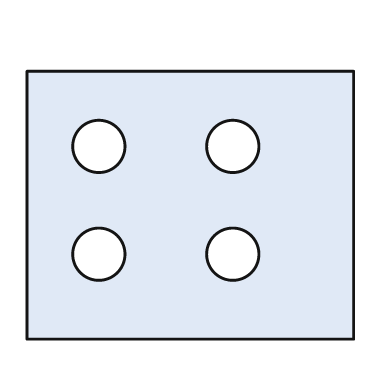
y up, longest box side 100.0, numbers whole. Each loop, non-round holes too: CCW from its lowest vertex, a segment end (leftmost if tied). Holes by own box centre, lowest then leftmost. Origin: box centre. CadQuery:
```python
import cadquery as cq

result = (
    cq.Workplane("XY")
    .moveTo(-50.0, -41.0)
    .lineTo(50.0, -41.0)
    .lineTo(50.0, 41.0)
    .lineTo(-50.0, 41.0)
    .close()
    .moveTo(-28.0, -15.0)
    .circle(8.0)
    .moveTo(13.0, -15.0)
    .circle(8.0)
    .moveTo(-28.0, 18.0)
    .circle(8.0)
    .moveTo(13.0, 18.0)
    .circle(8.0)
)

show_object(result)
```